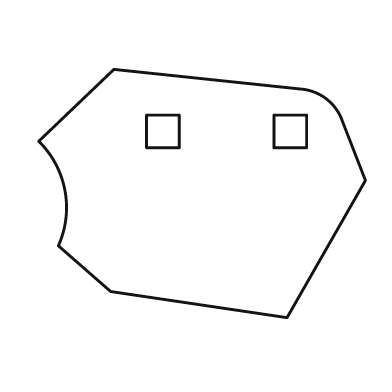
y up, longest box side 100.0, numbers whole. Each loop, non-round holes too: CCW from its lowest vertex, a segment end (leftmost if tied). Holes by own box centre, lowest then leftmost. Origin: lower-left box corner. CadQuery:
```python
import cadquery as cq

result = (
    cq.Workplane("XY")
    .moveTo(76.0, 0.0)
    .lineTo(100.0, 42.0)
    .lineTo(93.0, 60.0)
    .threePointArc((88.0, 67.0), (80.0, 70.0))
    .lineTo(23.0, 76.0)
    .lineTo(0.0, 54.0)
    .threePointArc((8.0, 39.0), (6.0, 22.0))
    .lineTo(22.0, 8.0)
    .close()
    .moveTo(33.0, 52.0)
    .lineTo(43.0, 52.0)
    .lineTo(43.0, 62.0)
    .lineTo(33.0, 62.0)
    .close()
    .moveTo(72.0, 52.0)
    .lineTo(82.0, 52.0)
    .lineTo(82.0, 62.0)
    .lineTo(72.0, 62.0)
    .close()
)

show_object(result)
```